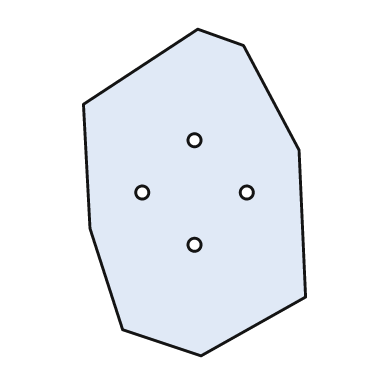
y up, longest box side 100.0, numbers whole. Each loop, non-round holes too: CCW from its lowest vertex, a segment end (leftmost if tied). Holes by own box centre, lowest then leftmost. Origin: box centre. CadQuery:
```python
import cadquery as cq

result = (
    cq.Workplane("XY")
    .moveTo(2.0, -50.0)
    .lineTo(34.0, -32.0)
    .lineTo(32.0, 13.0)
    .lineTo(15.0, 45.0)
    .lineTo(1.0, 50.0)
    .lineTo(-34.0, 27.0)
    .lineTo(-32.0, -11.0)
    .lineTo(-22.0, -42.0)
    .close()
    .moveTo(0.0, -16.0)
    .circle(2.0)
    .moveTo(-16.0, 0.0)
    .circle(2.0)
    .moveTo(16.0, 0.0)
    .circle(2.0)
    .moveTo(0.0, 16.0)
    .circle(2.0)
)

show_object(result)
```